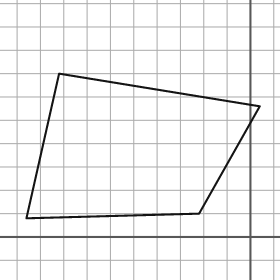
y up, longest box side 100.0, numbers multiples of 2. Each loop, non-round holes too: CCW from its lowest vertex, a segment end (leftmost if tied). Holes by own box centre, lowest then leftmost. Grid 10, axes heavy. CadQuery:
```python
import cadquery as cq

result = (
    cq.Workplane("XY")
    .moveTo(-96.0, 8.0)
    .lineTo(-22.0, 10.0)
    .lineTo(4.0, 56.0)
    .lineTo(-82.0, 70.0)
    .close()
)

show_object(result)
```